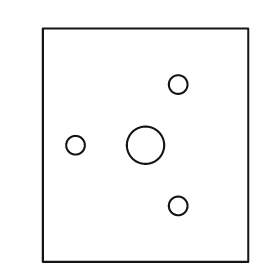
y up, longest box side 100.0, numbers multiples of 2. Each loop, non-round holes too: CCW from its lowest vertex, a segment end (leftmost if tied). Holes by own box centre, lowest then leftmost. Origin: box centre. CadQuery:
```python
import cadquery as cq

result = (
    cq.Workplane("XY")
    .moveTo(-44.0, -50.0)
    .lineTo(44.0, -50.0)
    .lineTo(44.0, 50.0)
    .lineTo(-44.0, 50.0)
    .close()
    .moveTo(14.0, -26.0)
    .circle(4.0)
    .moveTo(-30.0, 0.0)
    .circle(4.0)
    .moveTo(0.0, 0.0)
    .circle(8.0)
    .moveTo(14.0, 26.0)
    .circle(4.0)
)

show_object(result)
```